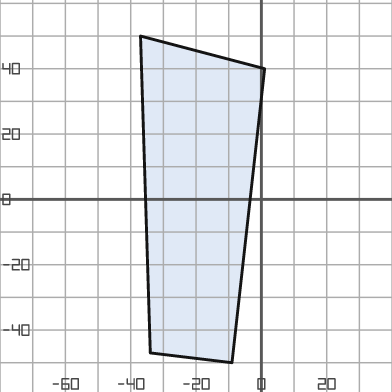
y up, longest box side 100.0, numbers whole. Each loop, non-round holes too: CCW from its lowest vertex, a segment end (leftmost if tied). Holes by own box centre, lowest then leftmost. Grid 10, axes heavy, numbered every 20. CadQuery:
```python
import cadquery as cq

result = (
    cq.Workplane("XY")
    .moveTo(-9.0, -50.0)
    .lineTo(1.0, 40.0)
    .lineTo(-37.0, 50.0)
    .lineTo(-34.0, -47.0)
    .close()
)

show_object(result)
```